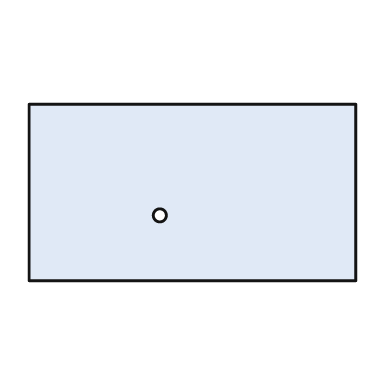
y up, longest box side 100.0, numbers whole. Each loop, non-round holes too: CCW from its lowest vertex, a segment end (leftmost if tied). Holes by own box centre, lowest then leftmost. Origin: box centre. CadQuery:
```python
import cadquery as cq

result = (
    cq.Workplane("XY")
    .moveTo(-50.0, -27.0)
    .lineTo(50.0, -27.0)
    .lineTo(50.0, 27.0)
    .lineTo(-50.0, 27.0)
    .close()
    .moveTo(-10.0, -7.0)
    .circle(2.0)
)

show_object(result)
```